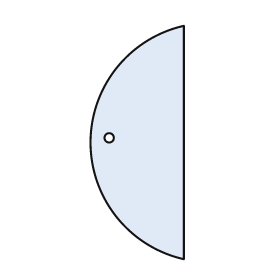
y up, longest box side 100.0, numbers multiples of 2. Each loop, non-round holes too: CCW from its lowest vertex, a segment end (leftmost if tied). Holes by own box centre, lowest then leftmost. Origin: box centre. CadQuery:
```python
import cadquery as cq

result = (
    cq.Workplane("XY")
    .moveTo(20.0, -50.0)
    .lineTo(20.0, 50.0)
    .threePointArc((-20.0, 0.0), (20.0, -50.0))
    .close()
    .moveTo(-12.0, 2.0)
    .circle(2.0)
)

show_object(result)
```